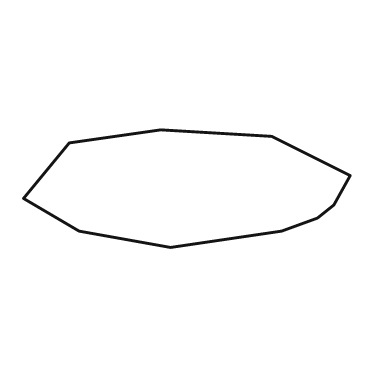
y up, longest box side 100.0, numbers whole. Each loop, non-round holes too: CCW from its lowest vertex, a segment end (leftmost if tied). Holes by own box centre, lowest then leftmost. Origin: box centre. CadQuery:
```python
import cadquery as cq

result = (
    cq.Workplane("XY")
    .moveTo(-5.0, -18.0)
    .lineTo(29.0, -13.0)
    .lineTo(40.0, -9.0)
    .lineTo(45.0, -5.0)
    .lineTo(50.0, 4.0)
    .lineTo(26.0, 16.0)
    .lineTo(-8.0, 18.0)
    .lineTo(-36.0, 14.0)
    .lineTo(-50.0, -3.0)
    .lineTo(-33.0, -13.0)
    .close()
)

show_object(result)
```